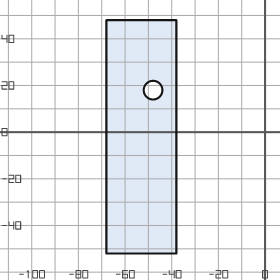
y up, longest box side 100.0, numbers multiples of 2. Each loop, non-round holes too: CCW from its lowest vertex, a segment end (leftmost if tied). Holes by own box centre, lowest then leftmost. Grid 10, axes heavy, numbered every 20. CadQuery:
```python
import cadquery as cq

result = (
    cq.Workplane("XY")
    .moveTo(-68.0, -52.0)
    .lineTo(-38.0, -52.0)
    .lineTo(-38.0, 48.0)
    .lineTo(-68.0, 48.0)
    .close()
    .moveTo(-48.0, 18.0)
    .circle(4.0)
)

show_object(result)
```